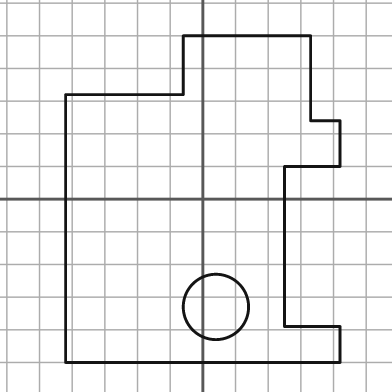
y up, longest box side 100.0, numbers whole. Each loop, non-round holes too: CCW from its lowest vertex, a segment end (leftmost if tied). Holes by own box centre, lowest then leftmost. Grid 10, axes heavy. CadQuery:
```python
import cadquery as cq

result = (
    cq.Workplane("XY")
    .moveTo(-42.0, -50.0)
    .lineTo(42.0, -50.0)
    .lineTo(42.0, -39.0)
    .lineTo(25.0, -39.0)
    .lineTo(25.0, 10.0)
    .lineTo(42.0, 10.0)
    .lineTo(42.0, 24.0)
    .lineTo(33.0, 24.0)
    .lineTo(33.0, 50.0)
    .lineTo(-6.0, 50.0)
    .lineTo(-6.0, 32.0)
    .lineTo(-42.0, 32.0)
    .close()
    .moveTo(4.0, -33.0)
    .circle(10.0)
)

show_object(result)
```